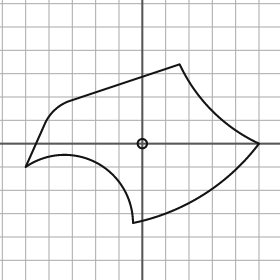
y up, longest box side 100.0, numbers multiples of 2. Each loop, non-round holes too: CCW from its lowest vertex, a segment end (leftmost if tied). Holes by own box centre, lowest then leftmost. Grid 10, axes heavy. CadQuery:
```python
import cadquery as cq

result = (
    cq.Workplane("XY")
    .moveTo(-4.0, -34.0)
    .threePointArc((26.0, -22.0), (50.0, 0.0))
    .threePointArc((30.0, 14.0), (16.0, 34.0))
    .lineTo(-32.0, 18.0)
    .threePointArc((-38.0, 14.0), (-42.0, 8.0))
    .lineTo(-50.0, -10.0)
    .threePointArc((-20.0, -8.0), (-4.0, -34.0))
    .close()
    .moveTo(0.0, 0.0)
    .circle(2.0)
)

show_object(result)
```